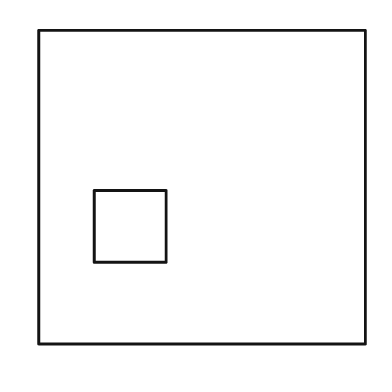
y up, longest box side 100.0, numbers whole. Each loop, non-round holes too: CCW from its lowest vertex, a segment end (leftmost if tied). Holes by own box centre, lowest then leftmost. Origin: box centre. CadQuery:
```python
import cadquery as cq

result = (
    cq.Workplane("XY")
    .moveTo(-50.0, -48.0)
    .lineTo(50.0, -48.0)
    .lineTo(50.0, 48.0)
    .lineTo(-50.0, 48.0)
    .close()
    .moveTo(-33.0, -23.0)
    .lineTo(-11.0, -23.0)
    .lineTo(-11.0, -1.0)
    .lineTo(-33.0, -1.0)
    .close()
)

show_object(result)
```